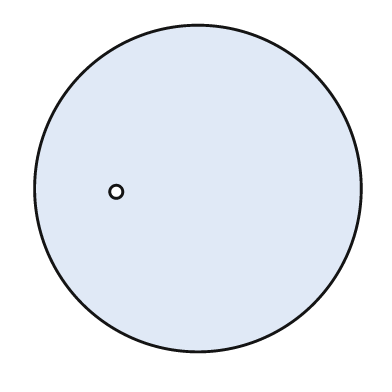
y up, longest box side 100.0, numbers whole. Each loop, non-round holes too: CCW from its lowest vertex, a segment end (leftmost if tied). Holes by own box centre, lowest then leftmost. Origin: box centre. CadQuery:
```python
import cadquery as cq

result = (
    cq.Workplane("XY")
    .moveTo(0.0, 0.0)
    .circle(50.0)
    .moveTo(-25.0, -1.0)
    .circle(2.0)
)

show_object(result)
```